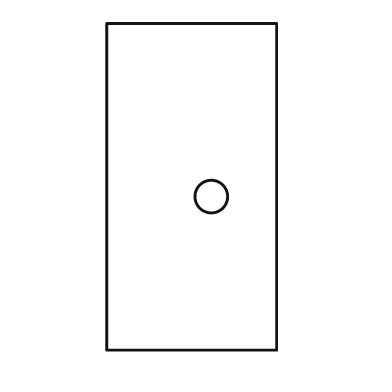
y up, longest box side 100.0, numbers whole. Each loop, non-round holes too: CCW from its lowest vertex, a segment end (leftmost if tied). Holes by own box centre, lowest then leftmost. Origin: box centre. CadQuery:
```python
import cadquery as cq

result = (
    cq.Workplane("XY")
    .moveTo(-26.0, -50.0)
    .lineTo(26.0, -50.0)
    .lineTo(26.0, 50.0)
    .lineTo(-26.0, 50.0)
    .close()
    .moveTo(6.0, -3.0)
    .circle(5.0)
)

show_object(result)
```